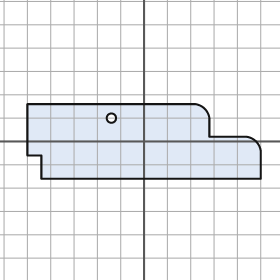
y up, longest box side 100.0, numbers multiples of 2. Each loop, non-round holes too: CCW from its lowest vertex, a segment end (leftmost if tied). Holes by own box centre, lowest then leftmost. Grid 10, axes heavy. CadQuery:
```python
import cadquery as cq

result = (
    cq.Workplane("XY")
    .moveTo(-44.0, -16.0)
    .lineTo(50.0, -16.0)
    .lineTo(50.0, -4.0)
    .threePointArc((48.0, 0.0), (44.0, 2.0))
    .lineTo(28.0, 2.0)
    .lineTo(28.0, 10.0)
    .threePointArc((26.0, 14.0), (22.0, 16.0))
    .lineTo(-50.0, 16.0)
    .lineTo(-50.0, -6.0)
    .lineTo(-44.0, -6.0)
    .close()
    .moveTo(-14.0, 10.0)
    .circle(2.0)
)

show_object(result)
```